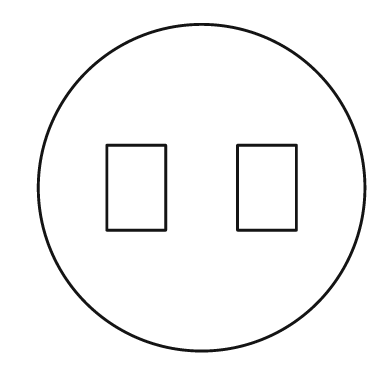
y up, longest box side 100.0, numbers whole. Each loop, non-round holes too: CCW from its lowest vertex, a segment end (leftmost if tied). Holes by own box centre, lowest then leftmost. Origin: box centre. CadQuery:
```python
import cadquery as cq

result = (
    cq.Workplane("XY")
    .moveTo(0.0, 0.0)
    .circle(50.0)
    .moveTo(-29.0, -13.0)
    .lineTo(-11.0, -13.0)
    .lineTo(-11.0, 13.0)
    .lineTo(-29.0, 13.0)
    .close()
    .moveTo(11.0, -13.0)
    .lineTo(29.0, -13.0)
    .lineTo(29.0, 13.0)
    .lineTo(11.0, 13.0)
    .close()
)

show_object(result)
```